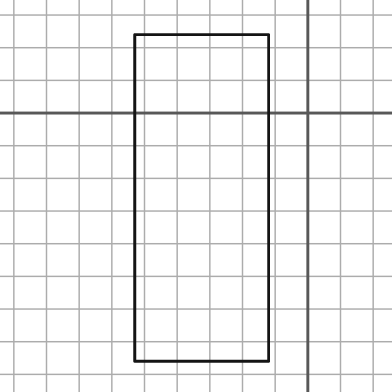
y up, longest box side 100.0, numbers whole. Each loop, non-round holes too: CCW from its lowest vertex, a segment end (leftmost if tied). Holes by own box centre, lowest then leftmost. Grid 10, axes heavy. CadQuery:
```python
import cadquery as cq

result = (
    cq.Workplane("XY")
    .moveTo(-53.0, -76.0)
    .lineTo(-12.0, -76.0)
    .lineTo(-12.0, 24.0)
    .lineTo(-53.0, 24.0)
    .close()
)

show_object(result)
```